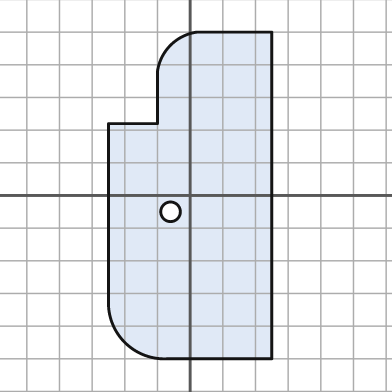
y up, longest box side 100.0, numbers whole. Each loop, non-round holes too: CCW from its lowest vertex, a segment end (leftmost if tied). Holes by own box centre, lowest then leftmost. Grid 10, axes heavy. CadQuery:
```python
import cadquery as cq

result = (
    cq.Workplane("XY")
    .moveTo(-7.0, -50.0)
    .lineTo(25.0, -50.0)
    .lineTo(25.0, 50.0)
    .lineTo(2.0, 50.0)
    .threePointArc((-6.0, 46.0), (-10.0, 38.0))
    .lineTo(-10.0, 22.0)
    .lineTo(-25.0, 22.0)
    .lineTo(-25.0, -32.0)
    .threePointArc((-20.0, -45.0), (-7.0, -50.0))
    .close()
    .moveTo(-6.0, -5.0)
    .circle(3.0)
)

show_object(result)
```